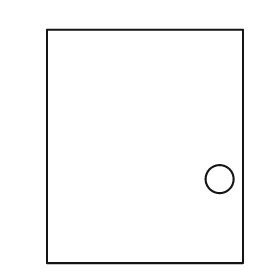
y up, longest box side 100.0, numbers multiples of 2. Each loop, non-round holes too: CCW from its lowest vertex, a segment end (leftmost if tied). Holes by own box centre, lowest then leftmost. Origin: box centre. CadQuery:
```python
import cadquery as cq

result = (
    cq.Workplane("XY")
    .moveTo(-42.0, -50.0)
    .lineTo(42.0, -50.0)
    .lineTo(42.0, 50.0)
    .lineTo(-42.0, 50.0)
    .close()
    .moveTo(32.0, -14.0)
    .circle(6.0)
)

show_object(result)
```